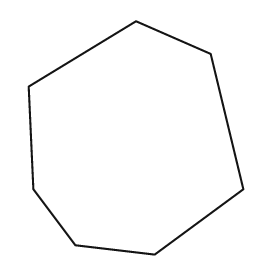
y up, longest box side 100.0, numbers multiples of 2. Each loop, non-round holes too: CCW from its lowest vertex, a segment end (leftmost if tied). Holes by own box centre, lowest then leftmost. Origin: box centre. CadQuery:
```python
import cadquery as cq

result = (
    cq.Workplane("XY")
    .moveTo(8.0, -50.0)
    .lineTo(46.0, -22.0)
    .lineTo(32.0, 36.0)
    .lineTo(0.0, 50.0)
    .lineTo(-46.0, 22.0)
    .lineTo(-44.0, -22.0)
    .lineTo(-26.0, -46.0)
    .close()
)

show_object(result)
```